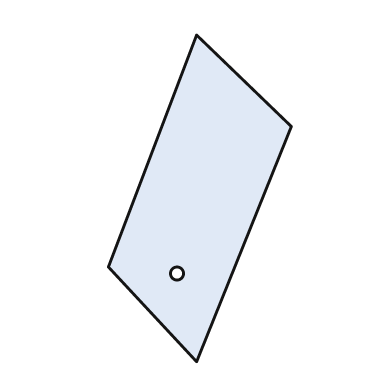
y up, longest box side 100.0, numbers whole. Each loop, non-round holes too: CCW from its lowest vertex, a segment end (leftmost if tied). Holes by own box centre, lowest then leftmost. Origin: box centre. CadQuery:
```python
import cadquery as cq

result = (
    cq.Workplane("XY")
    .moveTo(-1.0, -50.0)
    .lineTo(28.0, 22.0)
    .lineTo(-1.0, 50.0)
    .lineTo(-28.0, -21.0)
    .close()
    .moveTo(-7.0, -23.0)
    .circle(2.0)
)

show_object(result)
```